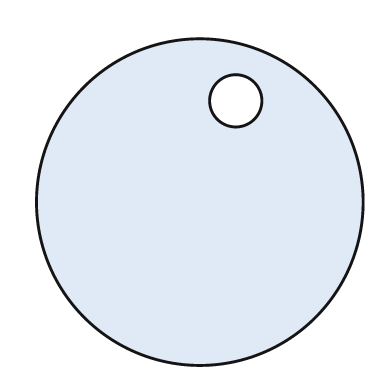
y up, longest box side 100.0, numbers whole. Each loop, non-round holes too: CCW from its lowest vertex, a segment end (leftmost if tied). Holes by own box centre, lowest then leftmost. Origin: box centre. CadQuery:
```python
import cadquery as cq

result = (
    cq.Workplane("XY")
    .moveTo(0.0, 0.0)
    .circle(50.0)
    .moveTo(11.0, 31.0)
    .circle(8.0)
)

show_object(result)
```